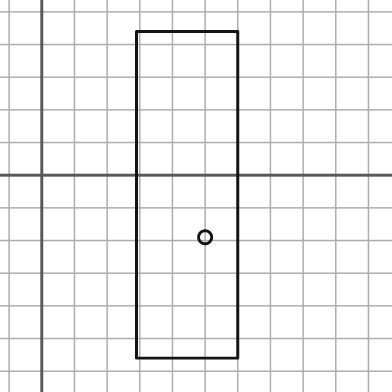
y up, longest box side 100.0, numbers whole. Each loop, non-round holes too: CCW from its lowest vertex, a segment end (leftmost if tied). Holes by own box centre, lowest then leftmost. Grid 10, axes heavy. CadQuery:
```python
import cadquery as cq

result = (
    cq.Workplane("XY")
    .moveTo(29.0, -56.0)
    .lineTo(60.0, -56.0)
    .lineTo(60.0, 44.0)
    .lineTo(29.0, 44.0)
    .close()
    .moveTo(50.0, -19.0)
    .circle(2.0)
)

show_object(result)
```